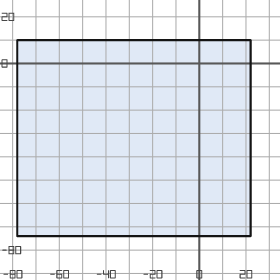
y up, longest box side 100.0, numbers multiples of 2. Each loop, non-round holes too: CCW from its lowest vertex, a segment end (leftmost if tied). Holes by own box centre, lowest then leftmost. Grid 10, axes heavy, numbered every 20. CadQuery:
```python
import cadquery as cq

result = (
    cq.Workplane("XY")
    .moveTo(-78.0, -74.0)
    .lineTo(22.0, -74.0)
    .lineTo(22.0, 10.0)
    .lineTo(-78.0, 10.0)
    .close()
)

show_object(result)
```